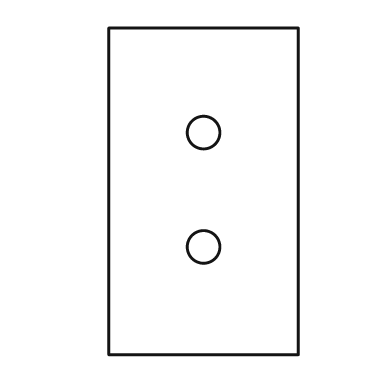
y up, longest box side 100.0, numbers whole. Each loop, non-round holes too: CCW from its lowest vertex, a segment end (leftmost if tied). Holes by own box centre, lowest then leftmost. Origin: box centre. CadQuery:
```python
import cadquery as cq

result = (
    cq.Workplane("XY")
    .moveTo(-29.0, -50.0)
    .lineTo(29.0, -50.0)
    .lineTo(29.0, 50.0)
    .lineTo(-29.0, 50.0)
    .close()
    .moveTo(0.0, -17.0)
    .circle(5.0)
    .moveTo(0.0, 18.0)
    .circle(5.0)
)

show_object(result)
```